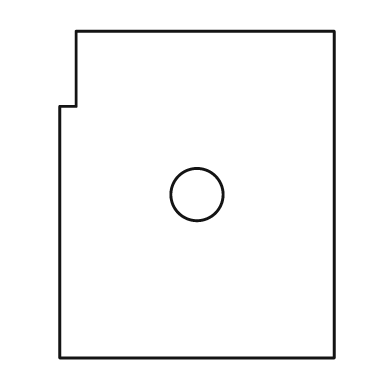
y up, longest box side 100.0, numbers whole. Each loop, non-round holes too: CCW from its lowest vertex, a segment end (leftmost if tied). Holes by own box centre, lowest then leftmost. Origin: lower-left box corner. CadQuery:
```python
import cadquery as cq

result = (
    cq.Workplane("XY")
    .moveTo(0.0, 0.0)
    .lineTo(84.0, 0.0)
    .lineTo(84.0, 100.0)
    .lineTo(5.0, 100.0)
    .lineTo(5.0, 77.0)
    .lineTo(0.0, 77.0)
    .close()
    .moveTo(42.0, 50.0)
    .circle(8.0)
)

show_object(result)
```